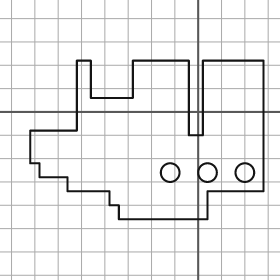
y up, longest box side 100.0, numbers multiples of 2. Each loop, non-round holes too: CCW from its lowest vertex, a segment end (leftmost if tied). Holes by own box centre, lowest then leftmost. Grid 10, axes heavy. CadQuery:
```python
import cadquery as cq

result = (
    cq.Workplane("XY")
    .moveTo(-34.0, -46.0)
    .lineTo(4.0, -46.0)
    .lineTo(4.0, -34.0)
    .lineTo(28.0, -34.0)
    .lineTo(28.0, 22.0)
    .lineTo(2.0, 22.0)
    .lineTo(2.0, -10.0)
    .lineTo(-4.0, -10.0)
    .lineTo(-4.0, 22.0)
    .lineTo(-28.0, 22.0)
    .lineTo(-28.0, 6.0)
    .lineTo(-46.0, 6.0)
    .lineTo(-46.0, 22.0)
    .lineTo(-52.0, 22.0)
    .lineTo(-52.0, -8.0)
    .lineTo(-72.0, -8.0)
    .lineTo(-72.0, -22.0)
    .lineTo(-68.0, -22.0)
    .lineTo(-68.0, -28.0)
    .lineTo(-56.0, -28.0)
    .lineTo(-56.0, -34.0)
    .lineTo(-38.0, -34.0)
    .lineTo(-38.0, -40.0)
    .lineTo(-34.0, -40.0)
    .close()
    .moveTo(-12.0, -26.0)
    .circle(4.0)
    .moveTo(4.0, -26.0)
    .circle(4.0)
    .moveTo(20.0, -26.0)
    .circle(4.0)
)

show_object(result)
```